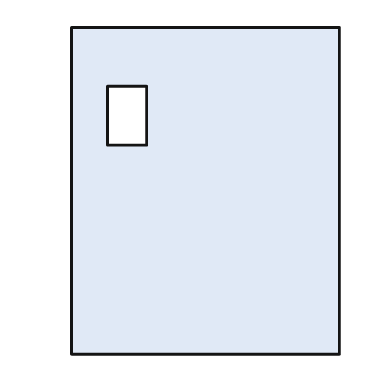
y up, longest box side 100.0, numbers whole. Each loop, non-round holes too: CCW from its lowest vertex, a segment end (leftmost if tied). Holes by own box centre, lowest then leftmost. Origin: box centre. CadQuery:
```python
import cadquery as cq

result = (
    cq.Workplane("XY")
    .moveTo(-41.0, -50.0)
    .lineTo(41.0, -50.0)
    .lineTo(41.0, 50.0)
    .lineTo(-41.0, 50.0)
    .close()
    .moveTo(-30.0, 14.0)
    .lineTo(-18.0, 14.0)
    .lineTo(-18.0, 32.0)
    .lineTo(-30.0, 32.0)
    .close()
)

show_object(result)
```